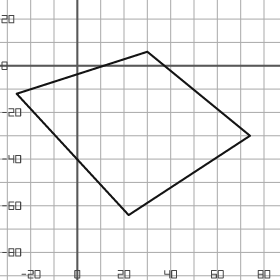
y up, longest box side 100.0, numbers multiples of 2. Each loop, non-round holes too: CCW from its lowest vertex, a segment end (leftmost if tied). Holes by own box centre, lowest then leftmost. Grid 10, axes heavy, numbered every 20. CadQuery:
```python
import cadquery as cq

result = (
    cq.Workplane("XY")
    .moveTo(22.0, -64.0)
    .lineTo(74.0, -30.0)
    .lineTo(30.0, 6.0)
    .lineTo(-26.0, -12.0)
    .close()
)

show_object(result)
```